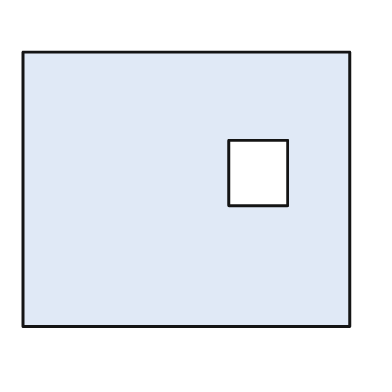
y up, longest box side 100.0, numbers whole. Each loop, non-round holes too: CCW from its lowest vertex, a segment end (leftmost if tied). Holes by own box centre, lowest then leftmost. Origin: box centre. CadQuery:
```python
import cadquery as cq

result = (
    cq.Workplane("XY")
    .moveTo(-50.0, -42.0)
    .lineTo(50.0, -42.0)
    .lineTo(50.0, 42.0)
    .lineTo(-50.0, 42.0)
    .close()
    .moveTo(13.0, -5.0)
    .lineTo(31.0, -5.0)
    .lineTo(31.0, 15.0)
    .lineTo(13.0, 15.0)
    .close()
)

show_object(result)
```